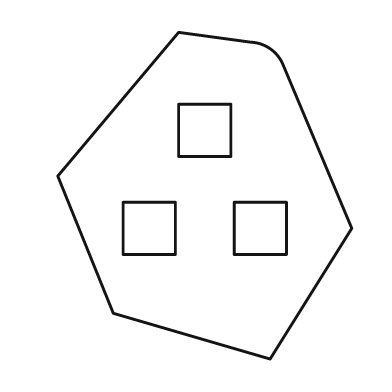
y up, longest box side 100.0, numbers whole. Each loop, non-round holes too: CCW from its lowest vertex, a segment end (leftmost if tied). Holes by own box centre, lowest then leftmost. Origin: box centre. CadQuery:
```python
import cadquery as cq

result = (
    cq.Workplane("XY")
    .moveTo(20.0, -50.0)
    .lineTo(45.0, -10.0)
    .lineTo(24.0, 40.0)
    .threePointArc((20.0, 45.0), (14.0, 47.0))
    .lineTo(-8.0, 50.0)
    .lineTo(-45.0, 6.0)
    .lineTo(-28.0, -36.0)
    .close()
    .moveTo(-25.0, -18.0)
    .lineTo(-9.0, -18.0)
    .lineTo(-9.0, -2.0)
    .lineTo(-25.0, -2.0)
    .close()
    .moveTo(9.0, -18.0)
    .lineTo(25.0, -18.0)
    .lineTo(25.0, -2.0)
    .lineTo(9.0, -2.0)
    .close()
    .moveTo(-8.0, 12.0)
    .lineTo(8.0, 12.0)
    .lineTo(8.0, 28.0)
    .lineTo(-8.0, 28.0)
    .close()
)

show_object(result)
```